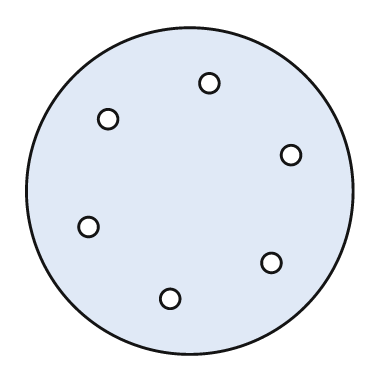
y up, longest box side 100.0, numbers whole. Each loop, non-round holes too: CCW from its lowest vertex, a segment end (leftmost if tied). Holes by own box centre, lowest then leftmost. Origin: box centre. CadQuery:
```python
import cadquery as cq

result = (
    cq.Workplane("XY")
    .moveTo(0.0, 0.0)
    .circle(50.0)
    .moveTo(-6.0, -33.0)
    .circle(3.0)
    .moveTo(25.0, -22.0)
    .circle(3.0)
    .moveTo(-31.0, -11.0)
    .circle(3.0)
    .moveTo(31.0, 11.0)
    .circle(3.0)
    .moveTo(-25.0, 22.0)
    .circle(3.0)
    .moveTo(6.0, 33.0)
    .circle(3.0)
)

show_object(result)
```